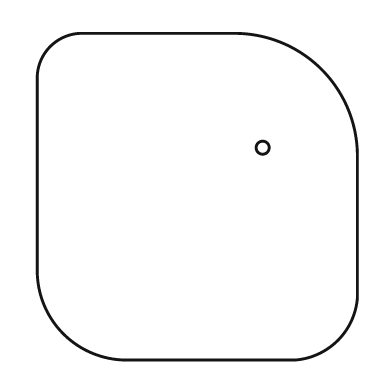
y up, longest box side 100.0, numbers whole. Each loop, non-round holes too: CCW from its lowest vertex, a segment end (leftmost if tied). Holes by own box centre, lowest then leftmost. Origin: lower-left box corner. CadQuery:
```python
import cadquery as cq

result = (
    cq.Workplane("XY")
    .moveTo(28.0, 0.0)
    .lineTo(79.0, 0.0)
    .threePointArc((92.0, 6.0), (98.0, 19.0))
    .lineTo(98.0, 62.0)
    .threePointArc((87.0, 89.0), (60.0, 100.0))
    .lineTo(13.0, 100.0)
    .threePointArc((4.0, 96.0), (0.0, 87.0))
    .lineTo(0.0, 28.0)
    .threePointArc((8.0, 8.0), (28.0, 0.0))
    .close()
    .moveTo(69.0, 65.0)
    .circle(2.0)
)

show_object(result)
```